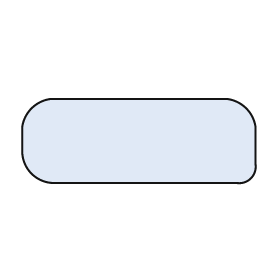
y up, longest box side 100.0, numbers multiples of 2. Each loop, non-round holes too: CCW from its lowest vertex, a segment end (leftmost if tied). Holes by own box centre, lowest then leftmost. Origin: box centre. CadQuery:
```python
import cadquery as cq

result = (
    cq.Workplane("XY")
    .moveTo(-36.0, -18.0)
    .lineTo(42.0, -18.0)
    .threePointArc((48.0, -16.0), (50.0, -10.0))
    .lineTo(50.0, 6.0)
    .threePointArc((46.0, 14.0), (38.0, 18.0))
    .lineTo(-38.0, 18.0)
    .threePointArc((-46.0, 14.0), (-50.0, 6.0))
    .lineTo(-50.0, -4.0)
    .threePointArc((-46.0, -14.0), (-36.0, -18.0))
    .close()
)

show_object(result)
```